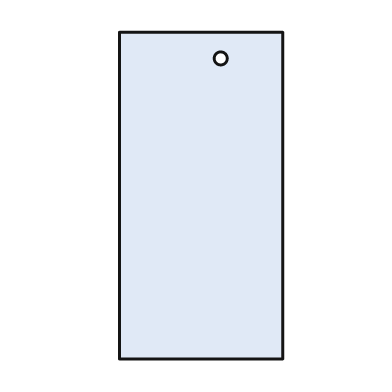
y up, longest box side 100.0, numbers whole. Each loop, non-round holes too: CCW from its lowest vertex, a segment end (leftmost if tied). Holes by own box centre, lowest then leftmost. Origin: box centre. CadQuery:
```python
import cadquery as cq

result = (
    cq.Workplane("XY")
    .moveTo(-25.0, -50.0)
    .lineTo(25.0, -50.0)
    .lineTo(25.0, 50.0)
    .lineTo(-25.0, 50.0)
    .close()
    .moveTo(6.0, 42.0)
    .circle(2.0)
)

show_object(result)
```